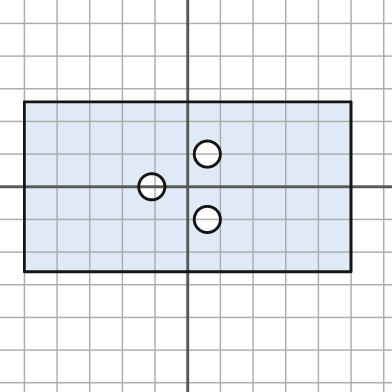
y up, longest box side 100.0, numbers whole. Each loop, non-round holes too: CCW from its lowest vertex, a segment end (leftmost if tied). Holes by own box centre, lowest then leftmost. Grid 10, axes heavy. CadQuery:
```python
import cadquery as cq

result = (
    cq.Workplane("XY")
    .moveTo(-50.0, -26.0)
    .lineTo(50.0, -26.0)
    .lineTo(50.0, 26.0)
    .lineTo(-50.0, 26.0)
    .close()
    .moveTo(6.0, -10.0)
    .circle(4.0)
    .moveTo(-11.0, 0.0)
    .circle(4.0)
    .moveTo(6.0, 10.0)
    .circle(4.0)
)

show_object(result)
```